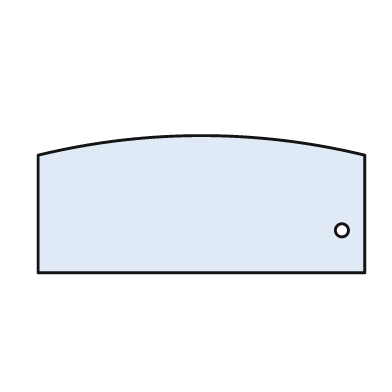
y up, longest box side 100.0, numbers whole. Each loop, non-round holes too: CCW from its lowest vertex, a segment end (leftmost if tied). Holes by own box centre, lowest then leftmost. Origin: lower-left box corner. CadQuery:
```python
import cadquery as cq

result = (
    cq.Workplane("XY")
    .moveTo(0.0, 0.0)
    .lineTo(100.0, 0.0)
    .lineTo(100.0, 36.0)
    .threePointArc((50.0, 42.0), (0.0, 36.0))
    .close()
    .moveTo(93.0, 13.0)
    .circle(2.0)
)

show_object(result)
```